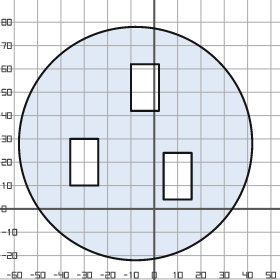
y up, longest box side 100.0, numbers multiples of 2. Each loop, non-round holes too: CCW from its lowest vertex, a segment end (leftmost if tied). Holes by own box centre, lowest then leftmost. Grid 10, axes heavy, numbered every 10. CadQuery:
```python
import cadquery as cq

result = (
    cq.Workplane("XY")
    .moveTo(-8.0, 28.0)
    .circle(50.0)
    .moveTo(4.0, 4.0)
    .lineTo(16.0, 4.0)
    .lineTo(16.0, 24.0)
    .lineTo(4.0, 24.0)
    .close()
    .moveTo(-36.0, 10.0)
    .lineTo(-24.0, 10.0)
    .lineTo(-24.0, 30.0)
    .lineTo(-36.0, 30.0)
    .close()
    .moveTo(-10.0, 42.0)
    .lineTo(2.0, 42.0)
    .lineTo(2.0, 62.0)
    .lineTo(-10.0, 62.0)
    .close()
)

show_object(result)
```